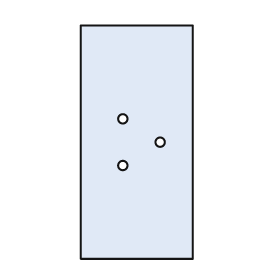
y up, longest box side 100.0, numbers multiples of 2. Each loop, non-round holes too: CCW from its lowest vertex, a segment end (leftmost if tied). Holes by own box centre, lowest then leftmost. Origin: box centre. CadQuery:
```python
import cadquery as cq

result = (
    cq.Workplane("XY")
    .moveTo(-24.0, -50.0)
    .lineTo(24.0, -50.0)
    .lineTo(24.0, 50.0)
    .lineTo(-24.0, 50.0)
    .close()
    .moveTo(-6.0, -10.0)
    .circle(2.0)
    .moveTo(10.0, 0.0)
    .circle(2.0)
    .moveTo(-6.0, 10.0)
    .circle(2.0)
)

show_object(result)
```